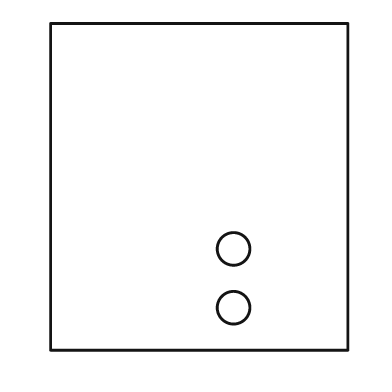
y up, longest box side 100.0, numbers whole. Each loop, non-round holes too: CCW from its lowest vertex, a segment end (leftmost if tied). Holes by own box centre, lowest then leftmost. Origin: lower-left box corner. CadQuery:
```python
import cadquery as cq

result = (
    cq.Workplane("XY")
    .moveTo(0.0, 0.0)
    .lineTo(91.0, 0.0)
    .lineTo(91.0, 100.0)
    .lineTo(0.0, 100.0)
    .close()
    .moveTo(56.0, 13.0)
    .circle(5.0)
    .moveTo(56.0, 31.0)
    .circle(5.0)
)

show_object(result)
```